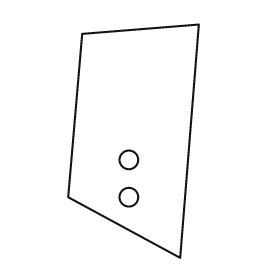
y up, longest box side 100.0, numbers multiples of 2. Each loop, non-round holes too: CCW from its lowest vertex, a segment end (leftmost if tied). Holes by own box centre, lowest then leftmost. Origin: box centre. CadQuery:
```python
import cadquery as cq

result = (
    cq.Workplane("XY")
    .moveTo(20.0, -50.0)
    .lineTo(28.0, 50.0)
    .lineTo(-22.0, 46.0)
    .lineTo(-28.0, -24.0)
    .close()
    .moveTo(-2.0, -24.0)
    .circle(4.0)
    .moveTo(-2.0, -8.0)
    .circle(4.0)
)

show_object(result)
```